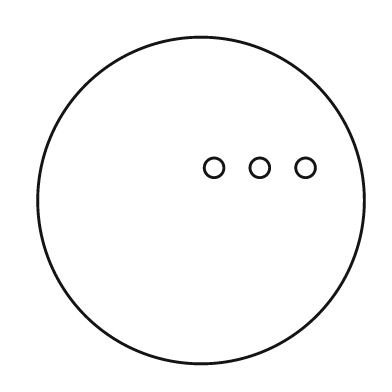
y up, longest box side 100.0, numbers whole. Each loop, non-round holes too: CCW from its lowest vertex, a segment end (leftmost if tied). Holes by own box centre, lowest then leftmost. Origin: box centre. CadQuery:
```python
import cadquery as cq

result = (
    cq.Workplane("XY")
    .moveTo(0.0, 0.0)
    .circle(50.0)
    .moveTo(4.0, 10.0)
    .circle(3.0)
    .moveTo(18.0, 10.0)
    .circle(3.0)
    .moveTo(32.0, 10.0)
    .circle(3.0)
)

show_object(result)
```